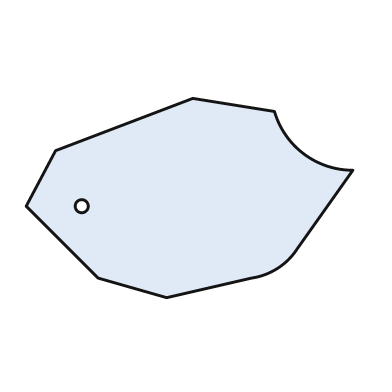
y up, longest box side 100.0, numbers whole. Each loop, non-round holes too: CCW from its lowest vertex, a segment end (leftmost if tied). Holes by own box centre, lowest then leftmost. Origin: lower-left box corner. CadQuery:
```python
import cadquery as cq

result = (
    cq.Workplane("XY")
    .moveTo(43.0, 0.0)
    .lineTo(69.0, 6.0)
    .threePointArc((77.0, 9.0), (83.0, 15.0))
    .lineTo(100.0, 39.0)
    .threePointArc((85.0, 44.0), (76.0, 57.0))
    .lineTo(51.0, 61.0)
    .lineTo(9.0, 45.0)
    .lineTo(0.0, 28.0)
    .lineTo(22.0, 6.0)
    .close()
    .moveTo(17.0, 28.0)
    .circle(2.0)
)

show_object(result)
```